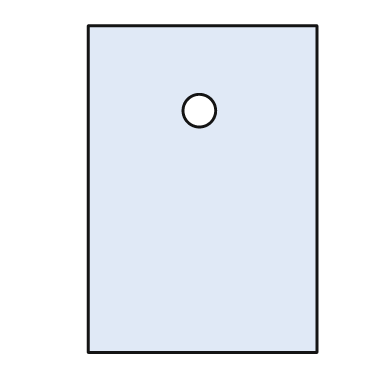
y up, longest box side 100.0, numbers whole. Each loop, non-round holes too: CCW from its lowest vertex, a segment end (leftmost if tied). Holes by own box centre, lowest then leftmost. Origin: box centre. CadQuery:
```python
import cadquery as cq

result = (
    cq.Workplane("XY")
    .moveTo(-35.0, -50.0)
    .lineTo(35.0, -50.0)
    .lineTo(35.0, 50.0)
    .lineTo(-35.0, 50.0)
    .close()
    .moveTo(-1.0, 24.0)
    .circle(5.0)
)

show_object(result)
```